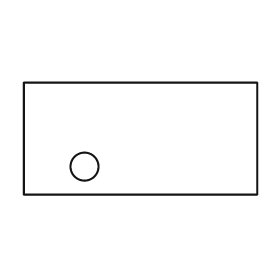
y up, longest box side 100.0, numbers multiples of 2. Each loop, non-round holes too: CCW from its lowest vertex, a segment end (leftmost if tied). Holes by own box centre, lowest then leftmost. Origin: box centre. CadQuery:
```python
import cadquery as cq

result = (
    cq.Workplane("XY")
    .moveTo(-50.0, -24.0)
    .lineTo(50.0, -24.0)
    .lineTo(50.0, 24.0)
    .lineTo(-50.0, 24.0)
    .close()
    .moveTo(-24.0, -12.0)
    .circle(6.0)
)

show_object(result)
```